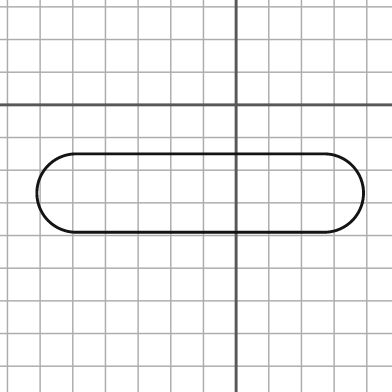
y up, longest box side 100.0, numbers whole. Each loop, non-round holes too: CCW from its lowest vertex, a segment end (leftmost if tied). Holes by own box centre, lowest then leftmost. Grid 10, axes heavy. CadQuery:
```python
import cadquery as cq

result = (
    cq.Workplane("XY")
    .moveTo(-49.0, -39.0)
    .lineTo(27.0, -39.0)
    .threePointArc((39.0, -27.0), (27.0, -15.0))
    .lineTo(-49.0, -15.0)
    .threePointArc((-61.0, -27.0), (-49.0, -39.0))
    .close()
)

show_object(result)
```